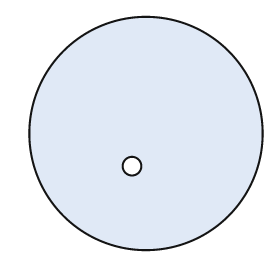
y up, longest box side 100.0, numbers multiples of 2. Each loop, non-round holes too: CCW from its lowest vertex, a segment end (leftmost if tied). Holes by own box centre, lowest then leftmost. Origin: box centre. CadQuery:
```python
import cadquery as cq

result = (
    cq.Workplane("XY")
    .moveTo(0.0, 0.0)
    .circle(50.0)
    .moveTo(-6.0, -14.0)
    .circle(4.0)
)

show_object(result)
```